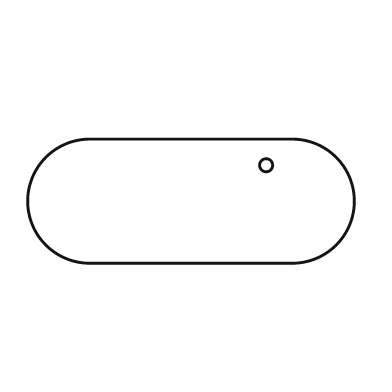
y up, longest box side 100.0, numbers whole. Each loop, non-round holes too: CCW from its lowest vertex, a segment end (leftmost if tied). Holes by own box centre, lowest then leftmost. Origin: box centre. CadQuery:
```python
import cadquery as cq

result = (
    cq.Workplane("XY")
    .moveTo(-31.0, -19.0)
    .lineTo(31.0, -19.0)
    .threePointArc((50.0, 0.0), (31.0, 19.0))
    .lineTo(-31.0, 19.0)
    .threePointArc((-50.0, 0.0), (-31.0, -19.0))
    .close()
    .moveTo(23.0, 11.0)
    .circle(2.0)
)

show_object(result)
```